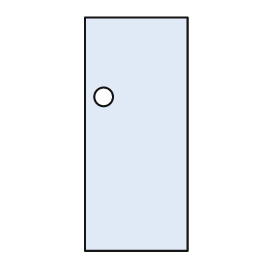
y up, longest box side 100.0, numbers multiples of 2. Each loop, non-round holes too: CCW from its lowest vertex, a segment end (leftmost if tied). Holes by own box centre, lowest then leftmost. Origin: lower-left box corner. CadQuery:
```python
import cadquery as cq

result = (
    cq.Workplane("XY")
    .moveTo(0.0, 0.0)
    .lineTo(44.0, 0.0)
    .lineTo(44.0, 100.0)
    .lineTo(0.0, 100.0)
    .close()
    .moveTo(8.0, 66.0)
    .circle(4.0)
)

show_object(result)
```